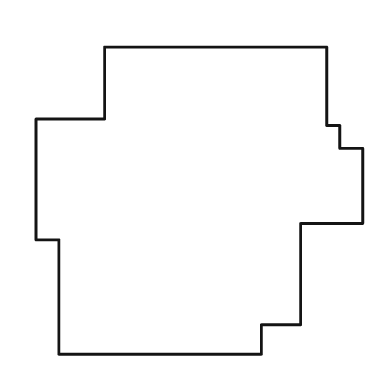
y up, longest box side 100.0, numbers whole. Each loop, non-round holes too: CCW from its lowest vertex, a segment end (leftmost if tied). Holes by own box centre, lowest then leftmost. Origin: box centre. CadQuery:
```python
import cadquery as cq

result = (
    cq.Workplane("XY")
    .moveTo(-43.0, -47.0)
    .lineTo(19.0, -47.0)
    .lineTo(19.0, -38.0)
    .lineTo(31.0, -38.0)
    .lineTo(31.0, -7.0)
    .lineTo(50.0, -7.0)
    .lineTo(50.0, 16.0)
    .lineTo(43.0, 16.0)
    .lineTo(43.0, 23.0)
    .lineTo(39.0, 23.0)
    .lineTo(39.0, 47.0)
    .lineTo(-29.0, 47.0)
    .lineTo(-29.0, 25.0)
    .lineTo(-50.0, 25.0)
    .lineTo(-50.0, -12.0)
    .lineTo(-43.0, -12.0)
    .close()
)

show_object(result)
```